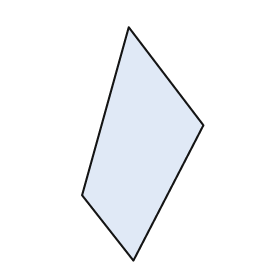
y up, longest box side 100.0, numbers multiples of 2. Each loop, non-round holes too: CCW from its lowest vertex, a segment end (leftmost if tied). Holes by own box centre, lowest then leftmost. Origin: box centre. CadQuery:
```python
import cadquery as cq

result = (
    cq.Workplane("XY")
    .moveTo(-4.0, -50.0)
    .lineTo(26.0, 8.0)
    .lineTo(-6.0, 50.0)
    .lineTo(-26.0, -22.0)
    .close()
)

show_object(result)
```